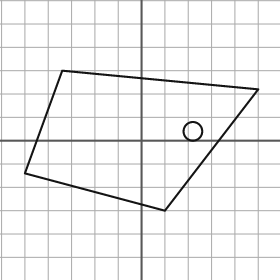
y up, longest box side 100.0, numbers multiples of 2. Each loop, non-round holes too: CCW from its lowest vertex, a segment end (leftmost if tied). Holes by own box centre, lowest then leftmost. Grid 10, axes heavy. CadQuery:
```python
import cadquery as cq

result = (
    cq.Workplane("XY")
    .moveTo(10.0, -30.0)
    .lineTo(50.0, 22.0)
    .lineTo(-34.0, 30.0)
    .lineTo(-50.0, -14.0)
    .close()
    .moveTo(22.0, 4.0)
    .circle(4.0)
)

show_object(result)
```